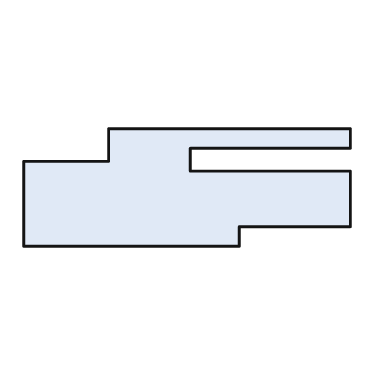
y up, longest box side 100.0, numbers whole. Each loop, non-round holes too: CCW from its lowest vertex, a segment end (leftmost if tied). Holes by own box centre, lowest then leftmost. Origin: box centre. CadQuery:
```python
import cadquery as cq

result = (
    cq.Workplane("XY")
    .moveTo(-50.0, -18.0)
    .lineTo(16.0, -18.0)
    .lineTo(16.0, -12.0)
    .lineTo(50.0, -12.0)
    .lineTo(50.0, 5.0)
    .lineTo(1.0, 5.0)
    .lineTo(1.0, 12.0)
    .lineTo(50.0, 12.0)
    .lineTo(50.0, 18.0)
    .lineTo(-24.0, 18.0)
    .lineTo(-24.0, 8.0)
    .lineTo(-50.0, 8.0)
    .close()
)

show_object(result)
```